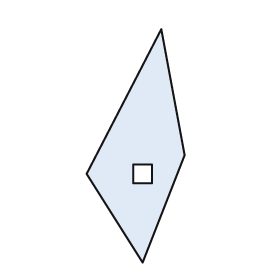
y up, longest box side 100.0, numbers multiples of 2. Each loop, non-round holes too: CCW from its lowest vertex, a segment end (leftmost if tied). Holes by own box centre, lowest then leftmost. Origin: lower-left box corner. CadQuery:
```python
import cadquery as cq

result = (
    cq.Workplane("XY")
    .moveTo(24.0, 0.0)
    .lineTo(42.0, 46.0)
    .lineTo(32.0, 100.0)
    .lineTo(0.0, 38.0)
    .close()
    .moveTo(20.0, 34.0)
    .lineTo(28.0, 34.0)
    .lineTo(28.0, 42.0)
    .lineTo(20.0, 42.0)
    .close()
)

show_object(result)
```